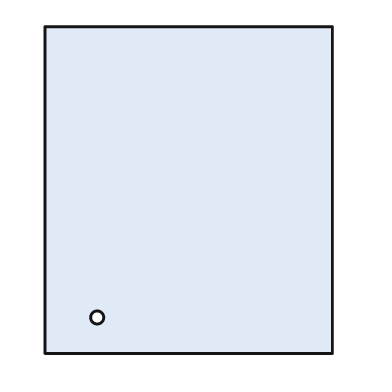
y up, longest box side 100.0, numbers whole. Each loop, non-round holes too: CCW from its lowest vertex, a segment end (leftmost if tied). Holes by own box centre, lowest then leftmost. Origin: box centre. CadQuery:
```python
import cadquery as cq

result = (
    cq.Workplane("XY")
    .moveTo(-44.0, -50.0)
    .lineTo(44.0, -50.0)
    .lineTo(44.0, 50.0)
    .lineTo(-44.0, 50.0)
    .close()
    .moveTo(-28.0, -39.0)
    .circle(2.0)
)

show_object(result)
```